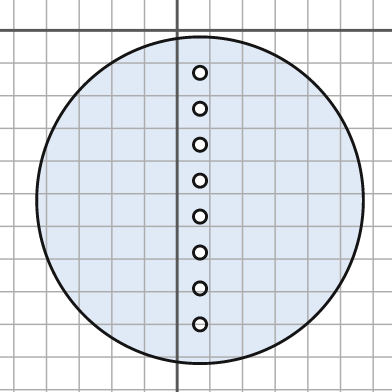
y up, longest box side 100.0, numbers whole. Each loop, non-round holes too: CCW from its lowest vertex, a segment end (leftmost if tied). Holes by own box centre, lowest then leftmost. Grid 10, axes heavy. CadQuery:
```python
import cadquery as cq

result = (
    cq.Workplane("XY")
    .moveTo(7.0, -52.0)
    .circle(50.0)
    .moveTo(7.0, -90.0)
    .circle(2.0)
    .moveTo(7.0, -79.0)
    .circle(2.0)
    .moveTo(7.0, -68.0)
    .circle(2.0)
    .moveTo(7.0, -57.0)
    .circle(2.0)
    .moveTo(7.0, -46.0)
    .circle(2.0)
    .moveTo(7.0, -35.0)
    .circle(2.0)
    .moveTo(7.0, -24.0)
    .circle(2.0)
    .moveTo(7.0, -13.0)
    .circle(2.0)
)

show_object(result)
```